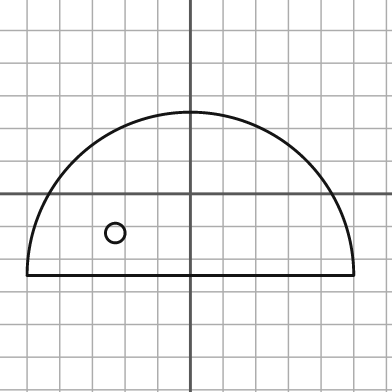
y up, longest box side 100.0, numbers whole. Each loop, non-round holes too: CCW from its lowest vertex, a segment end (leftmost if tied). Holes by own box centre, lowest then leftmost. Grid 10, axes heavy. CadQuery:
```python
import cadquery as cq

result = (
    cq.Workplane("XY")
    .moveTo(-50.0, -25.0)
    .lineTo(50.0, -25.0)
    .threePointArc((0.0, 25.0), (-50.0, -25.0))
    .close()
    .moveTo(-23.0, -12.0)
    .circle(3.0)
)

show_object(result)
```